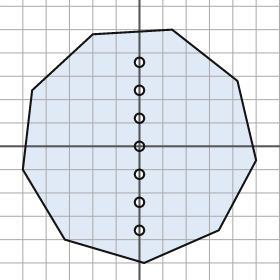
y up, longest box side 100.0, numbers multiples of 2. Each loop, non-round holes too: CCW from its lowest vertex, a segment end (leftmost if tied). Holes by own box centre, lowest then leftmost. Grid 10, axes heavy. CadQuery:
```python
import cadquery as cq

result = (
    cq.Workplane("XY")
    .moveTo(2.0, -50.0)
    .lineTo(34.0, -36.0)
    .lineTo(50.0, -6.0)
    .lineTo(42.0, 28.0)
    .lineTo(14.0, 50.0)
    .lineTo(-20.0, 48.0)
    .lineTo(-46.0, 24.0)
    .lineTo(-50.0, -10.0)
    .lineTo(-32.0, -40.0)
    .close()
    .moveTo(0.0, -36.0)
    .circle(2.0)
    .moveTo(0.0, -24.0)
    .circle(2.0)
    .moveTo(0.0, -12.0)
    .circle(2.0)
    .moveTo(0.0, 0.0)
    .circle(2.0)
    .moveTo(0.0, 12.0)
    .circle(2.0)
    .moveTo(0.0, 24.0)
    .circle(2.0)
    .moveTo(0.0, 36.0)
    .circle(2.0)
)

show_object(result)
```